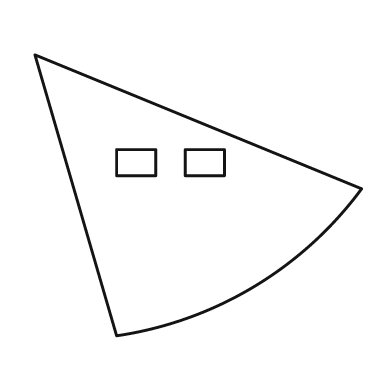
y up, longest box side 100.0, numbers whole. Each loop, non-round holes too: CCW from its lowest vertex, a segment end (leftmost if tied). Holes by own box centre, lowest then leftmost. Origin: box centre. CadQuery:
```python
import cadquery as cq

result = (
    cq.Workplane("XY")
    .moveTo(-25.0, -43.0)
    .threePointArc((17.0, -28.0), (50.0, 2.0))
    .lineTo(-50.0, 43.0)
    .close()
    .moveTo(-25.0, 6.0)
    .lineTo(-13.0, 6.0)
    .lineTo(-13.0, 14.0)
    .lineTo(-25.0, 14.0)
    .close()
    .moveTo(-4.0, 6.0)
    .lineTo(8.0, 6.0)
    .lineTo(8.0, 14.0)
    .lineTo(-4.0, 14.0)
    .close()
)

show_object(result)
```